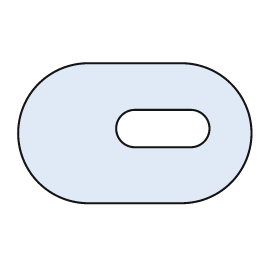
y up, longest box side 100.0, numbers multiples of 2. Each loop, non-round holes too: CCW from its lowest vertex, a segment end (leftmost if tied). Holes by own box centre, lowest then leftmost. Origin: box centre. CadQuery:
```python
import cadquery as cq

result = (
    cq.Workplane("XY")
    .moveTo(-20.0, -30.0)
    .lineTo(20.0, -30.0)
    .threePointArc((50.0, 0.0), (20.0, 30.0))
    .lineTo(-20.0, 30.0)
    .threePointArc((-50.0, 0.0), (-20.0, -30.0))
    .close()
    .moveTo(0.0, -6.0)
    .lineTo(24.0, -6.0)
    .threePointArc((32.0, 2.0), (24.0, 10.0))
    .lineTo(0.0, 10.0)
    .threePointArc((-8.0, 2.0), (0.0, -6.0))
    .close()
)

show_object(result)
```